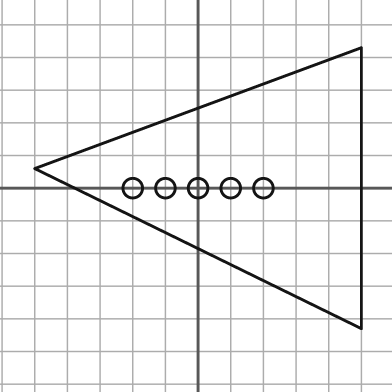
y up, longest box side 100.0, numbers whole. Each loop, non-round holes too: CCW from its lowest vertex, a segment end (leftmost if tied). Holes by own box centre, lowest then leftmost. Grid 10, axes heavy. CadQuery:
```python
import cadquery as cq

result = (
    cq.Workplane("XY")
    .moveTo(50.0, -43.0)
    .lineTo(50.0, 43.0)
    .lineTo(-50.0, 6.0)
    .close()
    .moveTo(-20.0, 0.0)
    .circle(3.0)
    .moveTo(-10.0, 0.0)
    .circle(3.0)
    .moveTo(0.0, 0.0)
    .circle(3.0)
    .moveTo(10.0, 0.0)
    .circle(3.0)
    .moveTo(20.0, 0.0)
    .circle(3.0)
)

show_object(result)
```